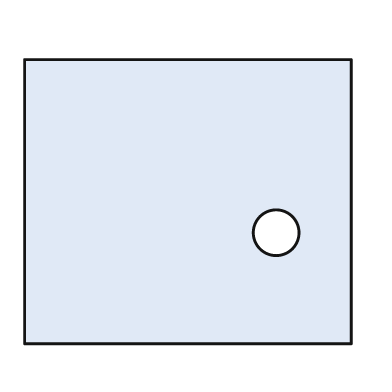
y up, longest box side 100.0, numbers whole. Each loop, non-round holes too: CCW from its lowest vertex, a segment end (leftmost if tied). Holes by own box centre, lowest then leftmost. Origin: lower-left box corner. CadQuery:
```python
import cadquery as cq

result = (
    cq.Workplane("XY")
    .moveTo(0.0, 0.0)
    .lineTo(100.0, 0.0)
    .lineTo(100.0, 87.0)
    .lineTo(0.0, 87.0)
    .close()
    .moveTo(77.0, 34.0)
    .circle(7.0)
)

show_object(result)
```